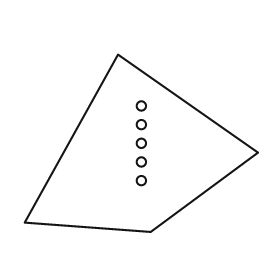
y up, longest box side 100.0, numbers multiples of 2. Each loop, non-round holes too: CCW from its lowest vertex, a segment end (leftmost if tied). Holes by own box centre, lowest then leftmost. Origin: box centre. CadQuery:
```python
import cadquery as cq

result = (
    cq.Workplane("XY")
    .moveTo(4.0, -38.0)
    .lineTo(50.0, -4.0)
    .lineTo(-10.0, 38.0)
    .lineTo(-50.0, -34.0)
    .close()
    .moveTo(0.0, -16.0)
    .circle(2.0)
    .moveTo(0.0, -8.0)
    .circle(2.0)
    .moveTo(0.0, 0.0)
    .circle(2.0)
    .moveTo(0.0, 8.0)
    .circle(2.0)
    .moveTo(0.0, 16.0)
    .circle(2.0)
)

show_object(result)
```